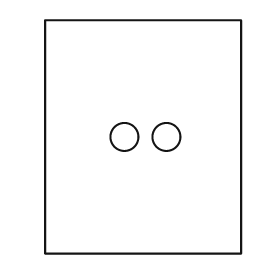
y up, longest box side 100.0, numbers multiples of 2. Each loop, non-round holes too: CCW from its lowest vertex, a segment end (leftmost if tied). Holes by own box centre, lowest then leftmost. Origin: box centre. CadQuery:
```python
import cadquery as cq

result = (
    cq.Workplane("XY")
    .moveTo(-42.0, -50.0)
    .lineTo(42.0, -50.0)
    .lineTo(42.0, 50.0)
    .lineTo(-42.0, 50.0)
    .close()
    .moveTo(-8.0, 0.0)
    .circle(6.0)
    .moveTo(10.0, 0.0)
    .circle(6.0)
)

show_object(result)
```